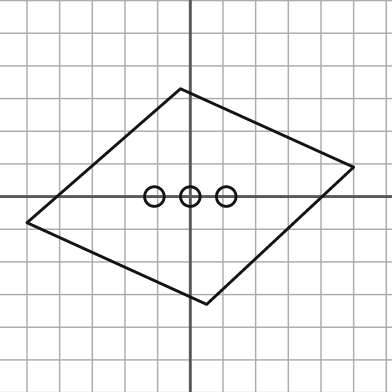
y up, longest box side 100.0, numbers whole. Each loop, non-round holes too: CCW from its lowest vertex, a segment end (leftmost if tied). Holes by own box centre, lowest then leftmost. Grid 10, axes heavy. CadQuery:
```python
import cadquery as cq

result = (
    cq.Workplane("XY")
    .moveTo(5.0, -33.0)
    .lineTo(50.0, 9.0)
    .lineTo(-3.0, 33.0)
    .lineTo(-50.0, -8.0)
    .close()
    .moveTo(-11.0, 0.0)
    .circle(3.0)
    .moveTo(0.0, 0.0)
    .circle(3.0)
    .moveTo(11.0, 0.0)
    .circle(3.0)
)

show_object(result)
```